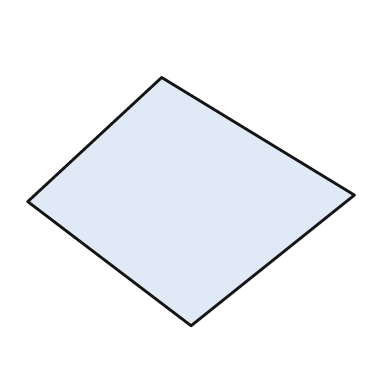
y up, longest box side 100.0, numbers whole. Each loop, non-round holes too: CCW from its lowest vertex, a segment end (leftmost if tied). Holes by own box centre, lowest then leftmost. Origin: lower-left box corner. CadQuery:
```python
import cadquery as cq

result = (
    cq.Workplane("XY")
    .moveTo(50.0, 0.0)
    .lineTo(100.0, 40.0)
    .lineTo(41.0, 76.0)
    .lineTo(0.0, 38.0)
    .close()
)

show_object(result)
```